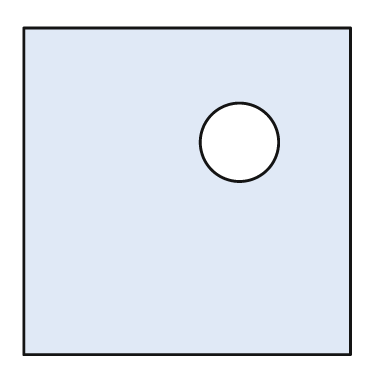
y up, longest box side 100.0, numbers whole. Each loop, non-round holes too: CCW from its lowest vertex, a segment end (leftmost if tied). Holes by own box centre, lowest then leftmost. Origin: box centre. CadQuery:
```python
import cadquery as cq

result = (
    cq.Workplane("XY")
    .moveTo(-50.0, -50.0)
    .lineTo(50.0, -50.0)
    .lineTo(50.0, 50.0)
    .lineTo(-50.0, 50.0)
    .close()
    .moveTo(16.0, 15.0)
    .circle(12.0)
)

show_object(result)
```